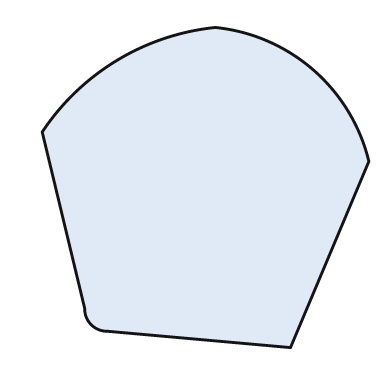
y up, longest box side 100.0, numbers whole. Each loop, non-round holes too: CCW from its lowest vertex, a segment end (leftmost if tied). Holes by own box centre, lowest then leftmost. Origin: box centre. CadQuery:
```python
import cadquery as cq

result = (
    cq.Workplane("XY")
    .moveTo(26.0, -49.0)
    .lineTo(50.0, 8.0)
    .threePointArc((33.0, 36.0), (3.0, 49.0))
    .threePointArc((-27.0, 39.0), (-50.0, 17.0))
    .lineTo(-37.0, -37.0)
    .threePointArc((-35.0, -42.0), (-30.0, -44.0))
    .close()
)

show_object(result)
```